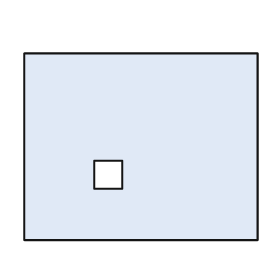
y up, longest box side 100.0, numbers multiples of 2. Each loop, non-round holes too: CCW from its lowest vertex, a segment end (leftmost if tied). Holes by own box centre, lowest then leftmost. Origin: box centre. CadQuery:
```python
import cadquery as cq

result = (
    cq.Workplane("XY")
    .moveTo(-50.0, -40.0)
    .lineTo(50.0, -40.0)
    .lineTo(50.0, 40.0)
    .lineTo(-50.0, 40.0)
    .close()
    .moveTo(-20.0, -18.0)
    .lineTo(-8.0, -18.0)
    .lineTo(-8.0, -6.0)
    .lineTo(-20.0, -6.0)
    .close()
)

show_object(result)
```